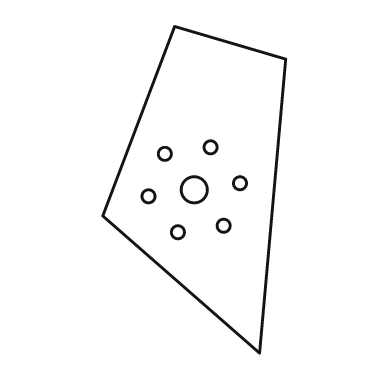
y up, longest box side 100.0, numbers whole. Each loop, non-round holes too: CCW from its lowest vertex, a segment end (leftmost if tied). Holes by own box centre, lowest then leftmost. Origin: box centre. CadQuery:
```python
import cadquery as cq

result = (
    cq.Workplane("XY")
    .moveTo(20.0, -50.0)
    .lineTo(28.0, 40.0)
    .lineTo(-6.0, 50.0)
    .lineTo(-28.0, -8.0)
    .close()
    .moveTo(-5.0, -13.0)
    .circle(2.0)
    .moveTo(9.0, -11.0)
    .circle(2.0)
    .moveTo(-14.0, -2.0)
    .circle(2.0)
    .moveTo(0.0, 0.0)
    .circle(4.0)
    .moveTo(14.0, 2.0)
    .circle(2.0)
    .moveTo(-9.0, 11.0)
    .circle(2.0)
    .moveTo(5.0, 13.0)
    .circle(2.0)
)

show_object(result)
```